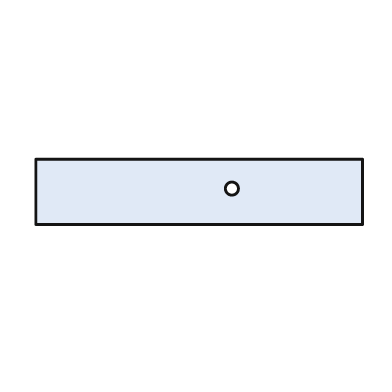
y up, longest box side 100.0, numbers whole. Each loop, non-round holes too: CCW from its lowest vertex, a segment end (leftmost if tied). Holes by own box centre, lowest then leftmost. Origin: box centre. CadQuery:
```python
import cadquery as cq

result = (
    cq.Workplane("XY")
    .moveTo(-50.0, -10.0)
    .lineTo(50.0, -10.0)
    .lineTo(50.0, 10.0)
    .lineTo(-50.0, 10.0)
    .close()
    .moveTo(10.0, 1.0)
    .circle(2.0)
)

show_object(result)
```